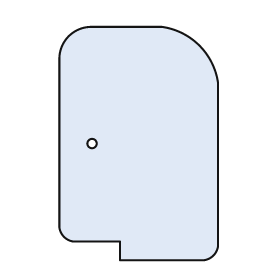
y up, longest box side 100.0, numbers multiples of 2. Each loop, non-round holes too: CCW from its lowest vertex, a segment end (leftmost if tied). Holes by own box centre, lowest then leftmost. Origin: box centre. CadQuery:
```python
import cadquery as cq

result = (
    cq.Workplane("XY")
    .moveTo(-8.0, -50.0)
    .lineTo(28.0, -50.0)
    .threePointArc((32.0, -48.0), (34.0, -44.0))
    .lineTo(34.0, 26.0)
    .threePointArc((26.0, 42.0), (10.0, 50.0))
    .lineTo(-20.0, 50.0)
    .threePointArc((-30.0, 46.0), (-34.0, 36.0))
    .lineTo(-34.0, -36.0)
    .threePointArc((-32.0, -40.0), (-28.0, -42.0))
    .lineTo(-8.0, -42.0)
    .close()
    .moveTo(-20.0, 0.0)
    .circle(2.0)
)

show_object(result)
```